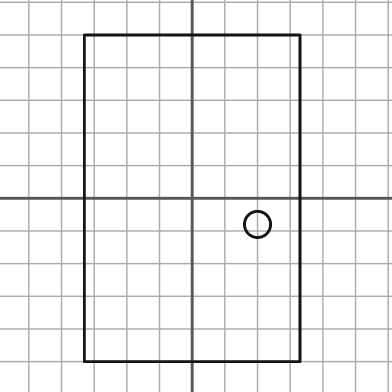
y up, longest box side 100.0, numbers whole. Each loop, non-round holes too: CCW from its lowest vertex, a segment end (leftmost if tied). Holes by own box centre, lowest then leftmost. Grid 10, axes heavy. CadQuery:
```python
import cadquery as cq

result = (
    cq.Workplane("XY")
    .moveTo(-33.0, -50.0)
    .lineTo(33.0, -50.0)
    .lineTo(33.0, 50.0)
    .lineTo(-33.0, 50.0)
    .close()
    .moveTo(20.0, -8.0)
    .circle(4.0)
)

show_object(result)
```